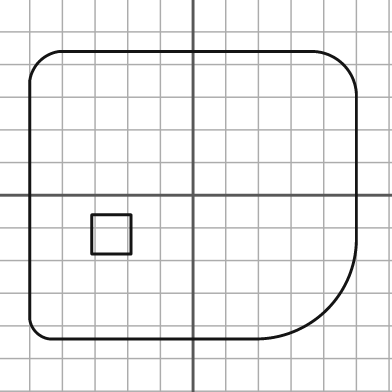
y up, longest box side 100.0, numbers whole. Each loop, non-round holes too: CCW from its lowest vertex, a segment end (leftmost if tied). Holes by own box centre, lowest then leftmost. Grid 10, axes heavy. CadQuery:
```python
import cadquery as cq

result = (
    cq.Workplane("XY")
    .moveTo(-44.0, -44.0)
    .lineTo(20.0, -44.0)
    .threePointArc((41.0, -35.0), (50.0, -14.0))
    .lineTo(50.0, 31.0)
    .threePointArc((46.0, 40.0), (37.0, 44.0))
    .lineTo(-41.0, 44.0)
    .threePointArc((-47.0, 41.0), (-50.0, 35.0))
    .lineTo(-50.0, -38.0)
    .threePointArc((-48.0, -42.0), (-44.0, -44.0))
    .close()
    .moveTo(-31.0, -18.0)
    .lineTo(-19.0, -18.0)
    .lineTo(-19.0, -6.0)
    .lineTo(-31.0, -6.0)
    .close()
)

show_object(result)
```